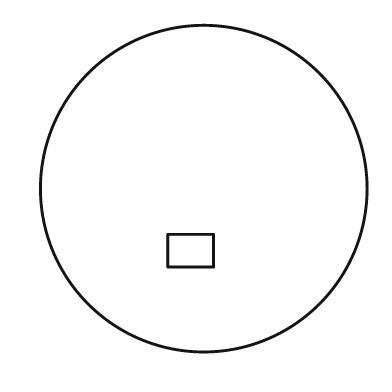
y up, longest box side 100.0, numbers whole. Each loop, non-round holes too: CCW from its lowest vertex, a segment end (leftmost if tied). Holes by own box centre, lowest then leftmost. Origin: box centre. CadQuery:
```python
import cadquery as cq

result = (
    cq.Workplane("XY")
    .moveTo(0.0, 0.0)
    .circle(50.0)
    .moveTo(-11.0, -24.0)
    .lineTo(3.0, -24.0)
    .lineTo(3.0, -14.0)
    .lineTo(-11.0, -14.0)
    .close()
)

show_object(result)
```